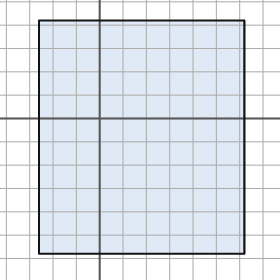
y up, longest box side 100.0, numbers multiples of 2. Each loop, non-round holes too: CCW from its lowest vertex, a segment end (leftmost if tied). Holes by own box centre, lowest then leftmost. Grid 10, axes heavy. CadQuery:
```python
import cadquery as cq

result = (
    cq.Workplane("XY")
    .moveTo(-26.0, -58.0)
    .lineTo(62.0, -58.0)
    .lineTo(62.0, 42.0)
    .lineTo(-26.0, 42.0)
    .close()
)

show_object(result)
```